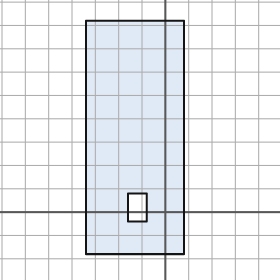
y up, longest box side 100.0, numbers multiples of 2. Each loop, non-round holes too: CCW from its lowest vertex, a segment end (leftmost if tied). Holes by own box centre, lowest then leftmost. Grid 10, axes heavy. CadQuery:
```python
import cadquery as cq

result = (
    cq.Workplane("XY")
    .moveTo(-34.0, -18.0)
    .lineTo(8.0, -18.0)
    .lineTo(8.0, 82.0)
    .lineTo(-34.0, 82.0)
    .close()
    .moveTo(-16.0, -4.0)
    .lineTo(-8.0, -4.0)
    .lineTo(-8.0, 8.0)
    .lineTo(-16.0, 8.0)
    .close()
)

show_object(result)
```